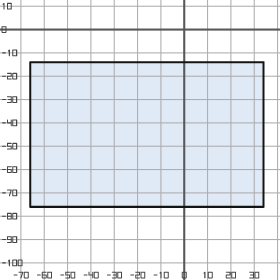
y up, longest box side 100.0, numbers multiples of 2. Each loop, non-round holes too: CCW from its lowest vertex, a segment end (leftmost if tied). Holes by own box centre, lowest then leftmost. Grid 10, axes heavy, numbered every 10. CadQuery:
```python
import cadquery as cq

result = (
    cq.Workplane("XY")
    .moveTo(-66.0, -76.0)
    .lineTo(34.0, -76.0)
    .lineTo(34.0, -14.0)
    .lineTo(-66.0, -14.0)
    .close()
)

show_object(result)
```